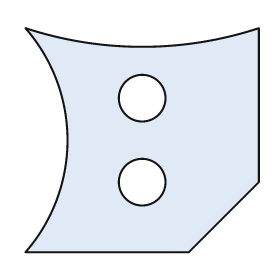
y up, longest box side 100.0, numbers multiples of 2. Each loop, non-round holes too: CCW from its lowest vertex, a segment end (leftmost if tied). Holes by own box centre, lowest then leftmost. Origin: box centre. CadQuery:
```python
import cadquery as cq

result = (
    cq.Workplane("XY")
    .moveTo(-50.0, -48.0)
    .lineTo(20.0, -48.0)
    .lineTo(50.0, -18.0)
    .lineTo(50.0, 48.0)
    .threePointArc((0.0, 40.0), (-50.0, 48.0))
    .threePointArc((-32.0, 0.0), (-50.0, -48.0))
    .close()
    .moveTo(0.0, -18.0)
    .circle(10.0)
    .moveTo(0.0, 18.0)
    .circle(10.0)
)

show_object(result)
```